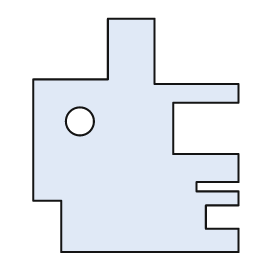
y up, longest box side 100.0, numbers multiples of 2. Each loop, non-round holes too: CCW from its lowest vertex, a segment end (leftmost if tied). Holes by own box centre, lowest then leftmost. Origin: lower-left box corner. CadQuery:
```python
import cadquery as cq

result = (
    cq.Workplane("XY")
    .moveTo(12.0, 0.0)
    .lineTo(88.0, 0.0)
    .lineTo(88.0, 10.0)
    .lineTo(74.0, 10.0)
    .lineTo(74.0, 20.0)
    .lineTo(88.0, 20.0)
    .lineTo(88.0, 26.0)
    .lineTo(70.0, 26.0)
    .lineTo(70.0, 30.0)
    .lineTo(88.0, 30.0)
    .lineTo(88.0, 42.0)
    .lineTo(60.0, 42.0)
    .lineTo(60.0, 64.0)
    .lineTo(88.0, 64.0)
    .lineTo(88.0, 72.0)
    .lineTo(52.0, 72.0)
    .lineTo(52.0, 100.0)
    .lineTo(32.0, 100.0)
    .lineTo(32.0, 74.0)
    .lineTo(0.0, 74.0)
    .lineTo(0.0, 22.0)
    .lineTo(12.0, 22.0)
    .close()
    .moveTo(20.0, 56.0)
    .circle(6.0)
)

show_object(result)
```